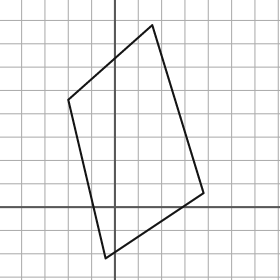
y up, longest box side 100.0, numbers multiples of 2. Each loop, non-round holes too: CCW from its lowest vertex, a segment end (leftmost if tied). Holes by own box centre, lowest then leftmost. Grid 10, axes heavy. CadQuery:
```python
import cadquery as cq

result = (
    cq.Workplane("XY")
    .moveTo(-4.0, -22.0)
    .lineTo(38.0, 6.0)
    .lineTo(16.0, 78.0)
    .lineTo(-20.0, 46.0)
    .close()
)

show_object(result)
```